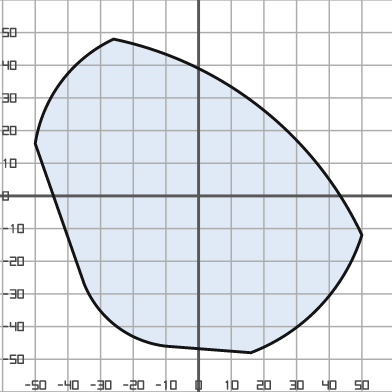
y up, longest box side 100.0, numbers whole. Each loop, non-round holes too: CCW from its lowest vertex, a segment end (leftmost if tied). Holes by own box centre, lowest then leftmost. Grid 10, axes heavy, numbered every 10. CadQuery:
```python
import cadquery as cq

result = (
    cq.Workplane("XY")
    .moveTo(16.0, -48.0)
    .threePointArc((37.0, -34.0), (50.0, -12.0))
    .threePointArc((19.0, 27.0), (-26.0, 48.0))
    .threePointArc((-42.0, 35.0), (-50.0, 16.0))
    .lineTo(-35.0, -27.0)
    .threePointArc((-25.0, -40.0), (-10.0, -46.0))
    .close()
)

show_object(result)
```